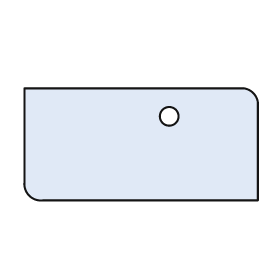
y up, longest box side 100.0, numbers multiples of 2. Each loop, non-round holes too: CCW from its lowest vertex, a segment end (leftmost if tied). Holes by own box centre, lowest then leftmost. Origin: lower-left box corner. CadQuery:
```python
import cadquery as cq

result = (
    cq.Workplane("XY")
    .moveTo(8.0, 0.0)
    .lineTo(100.0, 0.0)
    .lineTo(100.0, 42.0)
    .threePointArc((98.0, 46.0), (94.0, 48.0))
    .lineTo(0.0, 48.0)
    .lineTo(0.0, 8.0)
    .threePointArc((2.0, 2.0), (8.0, 0.0))
    .close()
    .moveTo(62.0, 36.0)
    .circle(4.0)
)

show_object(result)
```